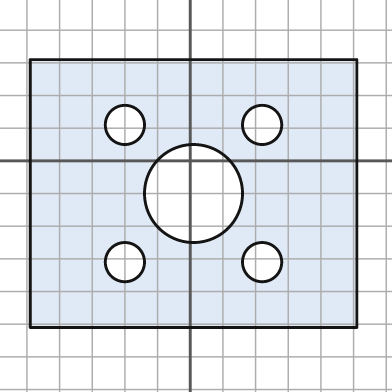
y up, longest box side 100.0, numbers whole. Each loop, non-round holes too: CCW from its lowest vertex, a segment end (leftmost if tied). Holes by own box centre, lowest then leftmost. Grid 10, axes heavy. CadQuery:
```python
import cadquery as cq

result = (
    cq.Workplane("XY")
    .moveTo(-49.0, -51.0)
    .lineTo(51.0, -51.0)
    .lineTo(51.0, 31.0)
    .lineTo(-49.0, 31.0)
    .close()
    .moveTo(-20.0, -31.0)
    .circle(6.0)
    .moveTo(22.0, -31.0)
    .circle(6.0)
    .moveTo(1.0, -10.0)
    .circle(15.0)
    .moveTo(-20.0, 11.0)
    .circle(6.0)
    .moveTo(22.0, 11.0)
    .circle(6.0)
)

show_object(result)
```